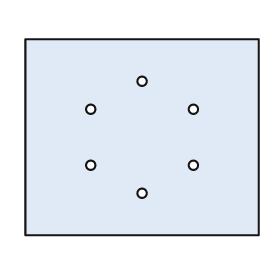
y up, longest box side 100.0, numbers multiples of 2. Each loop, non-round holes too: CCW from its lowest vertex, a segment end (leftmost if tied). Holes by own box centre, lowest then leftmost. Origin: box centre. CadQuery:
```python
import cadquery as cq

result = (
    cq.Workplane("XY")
    .moveTo(-50.0, -42.0)
    .lineTo(50.0, -42.0)
    .lineTo(50.0, 42.0)
    .lineTo(-50.0, 42.0)
    .close()
    .moveTo(0.0, -24.0)
    .circle(2.0)
    .moveTo(-22.0, -12.0)
    .circle(2.0)
    .moveTo(22.0, -12.0)
    .circle(2.0)
    .moveTo(-22.0, 12.0)
    .circle(2.0)
    .moveTo(22.0, 12.0)
    .circle(2.0)
    .moveTo(0.0, 24.0)
    .circle(2.0)
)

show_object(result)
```